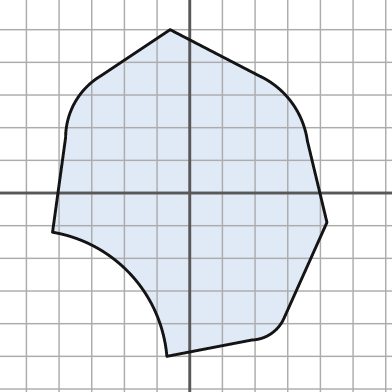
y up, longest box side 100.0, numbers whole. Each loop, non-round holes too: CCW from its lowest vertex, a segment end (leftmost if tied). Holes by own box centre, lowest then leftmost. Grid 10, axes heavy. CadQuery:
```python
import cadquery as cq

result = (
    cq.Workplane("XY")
    .moveTo(-7.0, -50.0)
    .lineTo(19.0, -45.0)
    .threePointArc((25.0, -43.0), (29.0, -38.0))
    .lineTo(42.0, -9.0)
    .lineTo(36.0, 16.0)
    .threePointArc((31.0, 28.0), (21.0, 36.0))
    .lineTo(-6.0, 50.0)
    .lineTo(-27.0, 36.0)
    .threePointArc((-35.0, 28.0), (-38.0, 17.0))
    .lineTo(-42.0, -12.0)
    .threePointArc((-18.0, -25.0), (-7.0, -50.0))
    .close()
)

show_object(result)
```